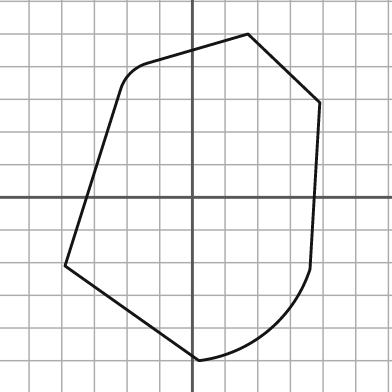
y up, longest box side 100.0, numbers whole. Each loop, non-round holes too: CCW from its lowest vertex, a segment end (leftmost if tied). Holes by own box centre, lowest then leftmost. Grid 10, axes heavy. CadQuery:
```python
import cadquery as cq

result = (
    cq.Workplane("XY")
    .moveTo(2.0, -50.0)
    .threePointArc((23.0, -41.0), (36.0, -22.0))
    .lineTo(39.0, 29.0)
    .lineTo(17.0, 50.0)
    .lineTo(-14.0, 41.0)
    .threePointArc((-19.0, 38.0), (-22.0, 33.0))
    .lineTo(-39.0, -21.0)
    .close()
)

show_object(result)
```